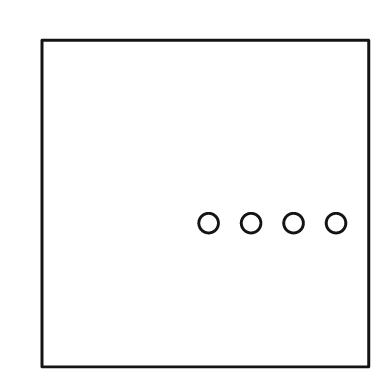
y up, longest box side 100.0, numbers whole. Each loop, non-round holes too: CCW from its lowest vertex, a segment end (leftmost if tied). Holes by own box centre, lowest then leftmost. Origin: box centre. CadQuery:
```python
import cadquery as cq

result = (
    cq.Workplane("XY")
    .moveTo(-50.0, -50.0)
    .lineTo(50.0, -50.0)
    .lineTo(50.0, 50.0)
    .lineTo(-50.0, 50.0)
    .close()
    .moveTo(1.0, -6.0)
    .circle(3.0)
    .moveTo(14.0, -6.0)
    .circle(3.0)
    .moveTo(27.0, -6.0)
    .circle(3.0)
    .moveTo(40.0, -6.0)
    .circle(3.0)
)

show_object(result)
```